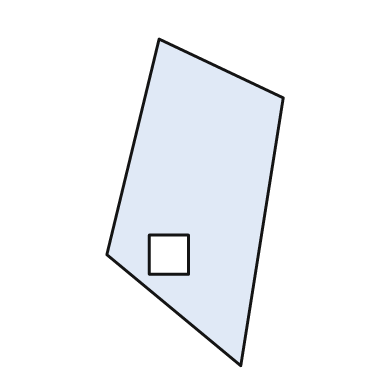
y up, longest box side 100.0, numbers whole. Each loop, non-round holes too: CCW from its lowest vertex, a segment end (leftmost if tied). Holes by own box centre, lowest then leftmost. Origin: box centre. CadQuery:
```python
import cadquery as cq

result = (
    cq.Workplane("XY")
    .moveTo(14.0, -50.0)
    .lineTo(27.0, 32.0)
    .lineTo(-11.0, 50.0)
    .lineTo(-27.0, -16.0)
    .close()
    .moveTo(-14.0, -22.0)
    .lineTo(-2.0, -22.0)
    .lineTo(-2.0, -10.0)
    .lineTo(-14.0, -10.0)
    .close()
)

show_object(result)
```